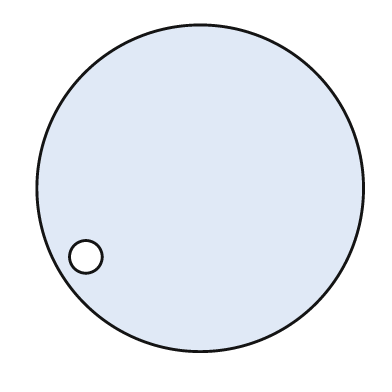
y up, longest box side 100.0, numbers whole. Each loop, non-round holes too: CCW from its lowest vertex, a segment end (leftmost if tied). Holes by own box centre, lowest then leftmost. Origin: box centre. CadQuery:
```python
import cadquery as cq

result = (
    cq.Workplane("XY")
    .moveTo(0.0, 0.0)
    .circle(50.0)
    .moveTo(-35.0, -21.0)
    .circle(5.0)
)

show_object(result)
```